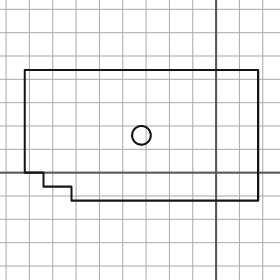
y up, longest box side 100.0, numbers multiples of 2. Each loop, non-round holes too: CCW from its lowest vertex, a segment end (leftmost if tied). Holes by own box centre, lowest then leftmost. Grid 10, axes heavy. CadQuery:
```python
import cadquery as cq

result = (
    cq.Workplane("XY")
    .moveTo(-62.0, -12.0)
    .lineTo(18.0, -12.0)
    .lineTo(18.0, 44.0)
    .lineTo(-82.0, 44.0)
    .lineTo(-82.0, 0.0)
    .lineTo(-74.0, 0.0)
    .lineTo(-74.0, -6.0)
    .lineTo(-62.0, -6.0)
    .close()
    .moveTo(-32.0, 16.0)
    .circle(4.0)
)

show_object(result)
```